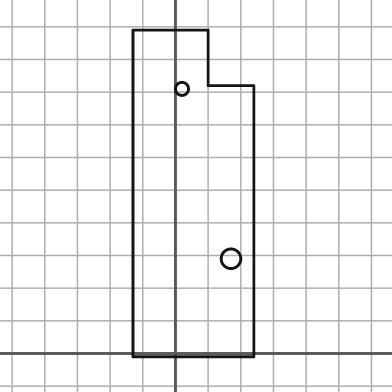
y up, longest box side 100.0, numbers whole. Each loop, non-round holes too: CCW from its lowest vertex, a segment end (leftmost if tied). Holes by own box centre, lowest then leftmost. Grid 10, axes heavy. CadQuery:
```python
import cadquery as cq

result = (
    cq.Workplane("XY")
    .moveTo(-13.0, -1.0)
    .lineTo(24.0, -1.0)
    .lineTo(24.0, 82.0)
    .lineTo(10.0, 82.0)
    .lineTo(10.0, 99.0)
    .lineTo(-13.0, 99.0)
    .close()
    .moveTo(17.0, 29.0)
    .circle(3.0)
    .moveTo(2.0, 81.0)
    .circle(2.0)
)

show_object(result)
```